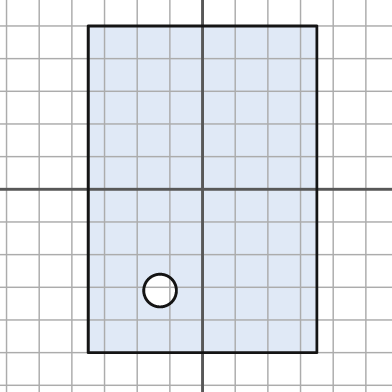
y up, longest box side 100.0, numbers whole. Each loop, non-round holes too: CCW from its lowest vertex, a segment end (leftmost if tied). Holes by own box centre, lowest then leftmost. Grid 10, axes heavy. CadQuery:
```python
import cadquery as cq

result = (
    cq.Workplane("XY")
    .moveTo(-35.0, -50.0)
    .lineTo(35.0, -50.0)
    .lineTo(35.0, 50.0)
    .lineTo(-35.0, 50.0)
    .close()
    .moveTo(-13.0, -31.0)
    .circle(5.0)
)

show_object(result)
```